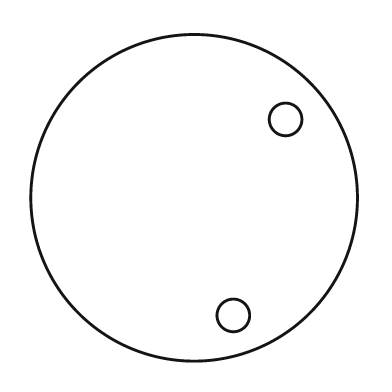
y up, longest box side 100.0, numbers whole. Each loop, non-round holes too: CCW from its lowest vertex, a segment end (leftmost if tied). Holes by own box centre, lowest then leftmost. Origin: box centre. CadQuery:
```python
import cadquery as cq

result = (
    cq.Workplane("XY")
    .moveTo(0.0, 0.0)
    .circle(50.0)
    .moveTo(12.0, -36.0)
    .circle(5.0)
    .moveTo(28.0, 24.0)
    .circle(5.0)
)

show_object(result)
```